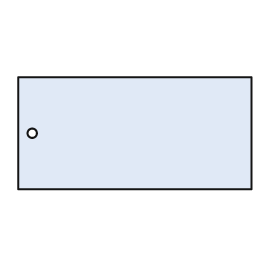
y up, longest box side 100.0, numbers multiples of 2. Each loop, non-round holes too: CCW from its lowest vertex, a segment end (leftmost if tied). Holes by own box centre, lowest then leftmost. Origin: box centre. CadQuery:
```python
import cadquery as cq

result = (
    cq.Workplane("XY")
    .moveTo(-50.0, -24.0)
    .lineTo(50.0, -24.0)
    .lineTo(50.0, 24.0)
    .lineTo(-50.0, 24.0)
    .close()
    .moveTo(-44.0, 0.0)
    .circle(2.0)
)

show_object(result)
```